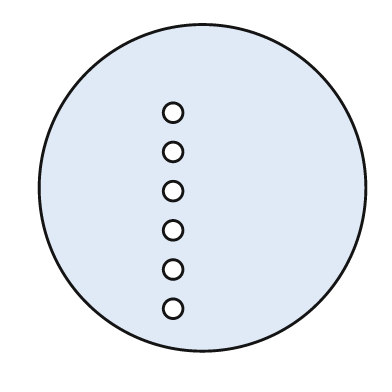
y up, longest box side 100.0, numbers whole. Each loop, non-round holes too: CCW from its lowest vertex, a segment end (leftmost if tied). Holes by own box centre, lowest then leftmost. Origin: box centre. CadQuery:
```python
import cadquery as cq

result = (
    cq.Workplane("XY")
    .moveTo(0.0, 0.0)
    .circle(50.0)
    .moveTo(-9.0, -37.0)
    .circle(3.0)
    .moveTo(-9.0, -25.0)
    .circle(3.0)
    .moveTo(-9.0, -13.0)
    .circle(3.0)
    .moveTo(-9.0, -1.0)
    .circle(3.0)
    .moveTo(-9.0, 11.0)
    .circle(3.0)
    .moveTo(-9.0, 23.0)
    .circle(3.0)
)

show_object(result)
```